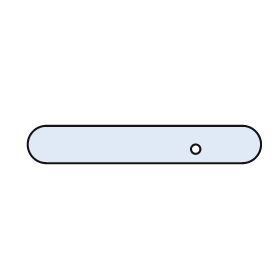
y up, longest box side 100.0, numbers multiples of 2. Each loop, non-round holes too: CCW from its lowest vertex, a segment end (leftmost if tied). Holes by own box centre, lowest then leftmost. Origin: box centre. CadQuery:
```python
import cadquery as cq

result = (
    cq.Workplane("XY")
    .moveTo(-42.0, -8.0)
    .lineTo(42.0, -8.0)
    .threePointArc((50.0, 0.0), (42.0, 8.0))
    .lineTo(-42.0, 8.0)
    .threePointArc((-50.0, 0.0), (-42.0, -8.0))
    .close()
    .moveTo(22.0, -2.0)
    .circle(2.0)
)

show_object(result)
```